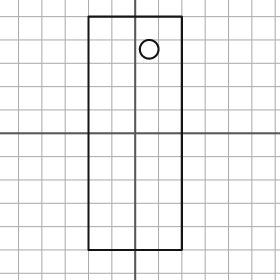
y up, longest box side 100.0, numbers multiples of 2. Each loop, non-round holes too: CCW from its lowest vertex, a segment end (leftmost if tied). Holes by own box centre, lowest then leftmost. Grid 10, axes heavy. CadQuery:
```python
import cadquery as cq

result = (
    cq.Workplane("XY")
    .moveTo(-20.0, -50.0)
    .lineTo(20.0, -50.0)
    .lineTo(20.0, 50.0)
    .lineTo(-20.0, 50.0)
    .close()
    .moveTo(6.0, 36.0)
    .circle(4.0)
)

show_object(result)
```